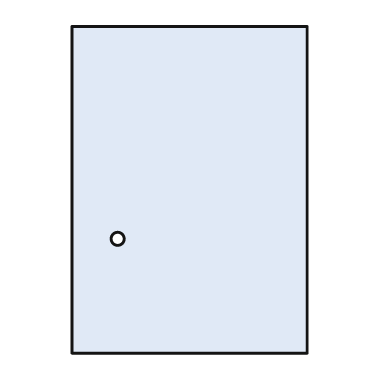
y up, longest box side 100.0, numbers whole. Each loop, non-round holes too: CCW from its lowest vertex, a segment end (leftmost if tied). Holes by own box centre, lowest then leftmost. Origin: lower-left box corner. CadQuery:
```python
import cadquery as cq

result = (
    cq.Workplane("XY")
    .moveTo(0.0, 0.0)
    .lineTo(72.0, 0.0)
    .lineTo(72.0, 100.0)
    .lineTo(0.0, 100.0)
    .close()
    .moveTo(14.0, 35.0)
    .circle(2.0)
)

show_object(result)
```